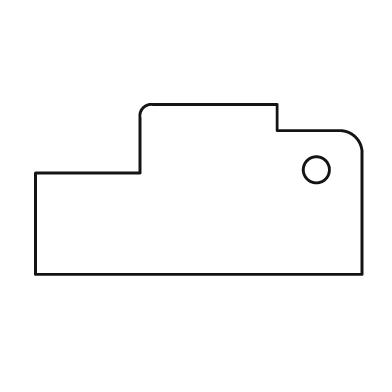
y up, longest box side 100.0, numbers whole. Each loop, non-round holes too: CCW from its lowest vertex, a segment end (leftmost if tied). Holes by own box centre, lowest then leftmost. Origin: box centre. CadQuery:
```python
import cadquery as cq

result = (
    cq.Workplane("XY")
    .moveTo(-50.0, -26.0)
    .lineTo(50.0, -26.0)
    .lineTo(50.0, 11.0)
    .threePointArc((48.0, 16.0), (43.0, 18.0))
    .lineTo(24.0, 18.0)
    .lineTo(24.0, 26.0)
    .lineTo(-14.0, 26.0)
    .threePointArc((-17.0, 25.0), (-18.0, 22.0))
    .lineTo(-18.0, 5.0)
    .lineTo(-50.0, 5.0)
    .close()
    .moveTo(36.0, 6.0)
    .circle(4.0)
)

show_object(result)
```